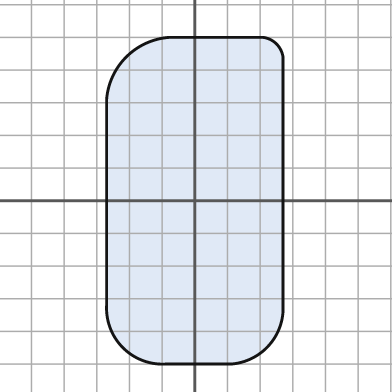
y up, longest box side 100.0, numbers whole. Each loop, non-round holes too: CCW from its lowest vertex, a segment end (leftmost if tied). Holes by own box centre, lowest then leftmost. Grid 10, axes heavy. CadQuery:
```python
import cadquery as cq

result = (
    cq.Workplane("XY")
    .moveTo(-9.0, -50.0)
    .lineTo(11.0, -50.0)
    .threePointArc((22.0, -45.0), (27.0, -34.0))
    .lineTo(27.0, 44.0)
    .threePointArc((25.0, 48.0), (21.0, 50.0))
    .lineTo(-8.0, 50.0)
    .threePointArc((-21.0, 44.0), (-27.0, 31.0))
    .lineTo(-27.0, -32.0)
    .threePointArc((-22.0, -45.0), (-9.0, -50.0))
    .close()
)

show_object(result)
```